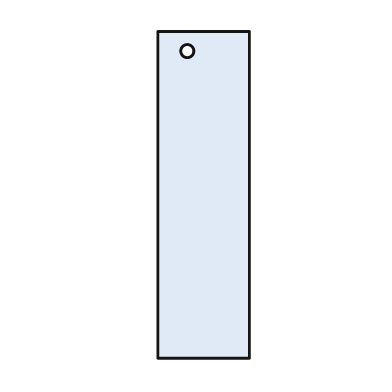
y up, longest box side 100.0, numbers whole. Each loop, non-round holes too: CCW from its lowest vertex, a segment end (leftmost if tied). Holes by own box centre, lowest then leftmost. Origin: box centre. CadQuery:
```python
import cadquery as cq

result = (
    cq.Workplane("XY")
    .moveTo(-14.0, -50.0)
    .lineTo(14.0, -50.0)
    .lineTo(14.0, 50.0)
    .lineTo(-14.0, 50.0)
    .close()
    .moveTo(-5.0, 44.0)
    .circle(2.0)
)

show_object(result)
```